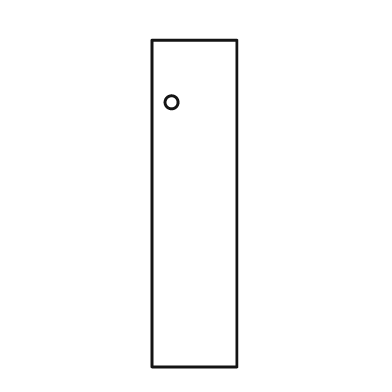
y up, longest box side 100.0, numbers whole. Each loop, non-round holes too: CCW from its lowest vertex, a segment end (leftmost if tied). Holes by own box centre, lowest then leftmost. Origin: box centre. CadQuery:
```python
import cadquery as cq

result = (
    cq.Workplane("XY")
    .moveTo(-13.0, -50.0)
    .lineTo(13.0, -50.0)
    .lineTo(13.0, 50.0)
    .lineTo(-13.0, 50.0)
    .close()
    .moveTo(-7.0, 31.0)
    .circle(2.0)
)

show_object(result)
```